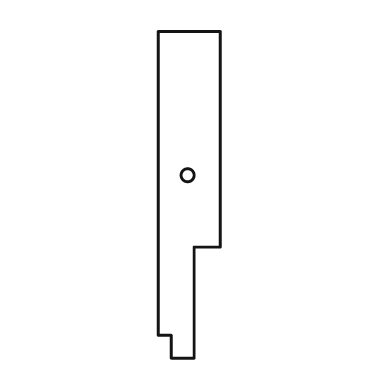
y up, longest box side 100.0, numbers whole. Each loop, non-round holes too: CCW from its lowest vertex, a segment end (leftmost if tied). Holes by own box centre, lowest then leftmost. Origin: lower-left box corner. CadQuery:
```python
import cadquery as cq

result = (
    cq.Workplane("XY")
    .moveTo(4.0, 0.0)
    .lineTo(11.0, 0.0)
    .lineTo(11.0, 34.0)
    .lineTo(19.0, 34.0)
    .lineTo(19.0, 100.0)
    .lineTo(0.0, 100.0)
    .lineTo(0.0, 7.0)
    .lineTo(4.0, 7.0)
    .close()
    .moveTo(9.0, 56.0)
    .circle(2.0)
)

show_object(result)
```